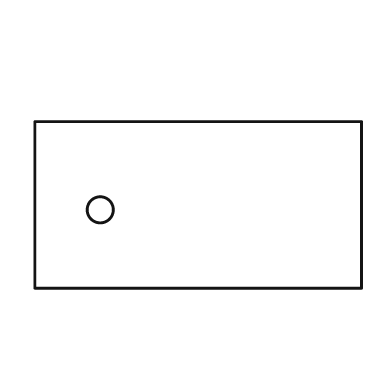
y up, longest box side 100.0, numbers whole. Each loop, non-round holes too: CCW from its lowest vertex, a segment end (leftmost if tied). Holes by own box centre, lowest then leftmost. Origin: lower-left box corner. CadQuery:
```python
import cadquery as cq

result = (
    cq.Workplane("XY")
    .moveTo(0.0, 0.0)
    .lineTo(100.0, 0.0)
    .lineTo(100.0, 51.0)
    .lineTo(0.0, 51.0)
    .close()
    .moveTo(20.0, 24.0)
    .circle(4.0)
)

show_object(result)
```